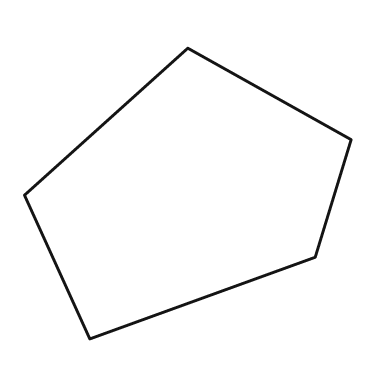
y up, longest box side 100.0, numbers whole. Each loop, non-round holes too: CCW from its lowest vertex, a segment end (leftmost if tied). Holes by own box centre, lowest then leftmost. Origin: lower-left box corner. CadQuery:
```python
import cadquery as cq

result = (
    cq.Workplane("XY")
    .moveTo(20.0, 0.0)
    .lineTo(89.0, 25.0)
    .lineTo(100.0, 61.0)
    .lineTo(50.0, 89.0)
    .lineTo(0.0, 44.0)
    .close()
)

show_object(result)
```